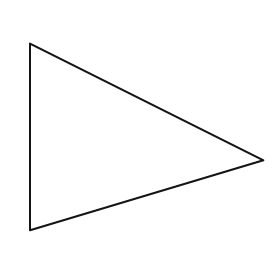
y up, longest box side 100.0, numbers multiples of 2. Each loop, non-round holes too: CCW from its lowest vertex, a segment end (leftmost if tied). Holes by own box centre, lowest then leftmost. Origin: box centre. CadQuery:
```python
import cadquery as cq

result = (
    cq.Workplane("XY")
    .moveTo(-50.0, -40.0)
    .lineTo(50.0, -10.0)
    .lineTo(-50.0, 40.0)
    .close()
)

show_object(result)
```